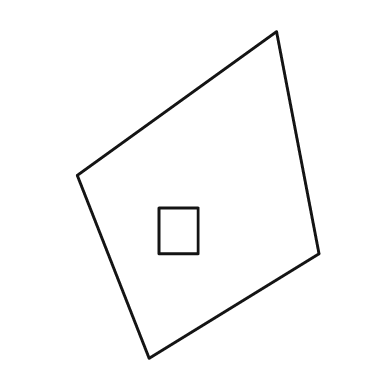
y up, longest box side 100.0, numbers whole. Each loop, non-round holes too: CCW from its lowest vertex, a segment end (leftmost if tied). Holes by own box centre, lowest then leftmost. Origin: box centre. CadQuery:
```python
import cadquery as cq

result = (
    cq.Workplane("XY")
    .moveTo(-15.0, -50.0)
    .lineTo(37.0, -18.0)
    .lineTo(24.0, 50.0)
    .lineTo(-37.0, 6.0)
    .close()
    .moveTo(-12.0, -18.0)
    .lineTo(0.0, -18.0)
    .lineTo(0.0, -4.0)
    .lineTo(-12.0, -4.0)
    .close()
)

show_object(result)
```